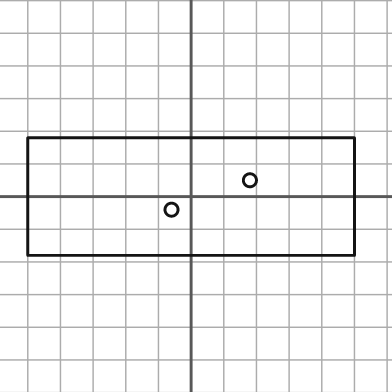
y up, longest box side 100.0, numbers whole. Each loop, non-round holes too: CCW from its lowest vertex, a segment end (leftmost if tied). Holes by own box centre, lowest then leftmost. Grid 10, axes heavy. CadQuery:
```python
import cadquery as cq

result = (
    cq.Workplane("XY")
    .moveTo(-50.0, -18.0)
    .lineTo(50.0, -18.0)
    .lineTo(50.0, 18.0)
    .lineTo(-50.0, 18.0)
    .close()
    .moveTo(-6.0, -4.0)
    .circle(2.0)
    .moveTo(18.0, 5.0)
    .circle(2.0)
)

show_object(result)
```